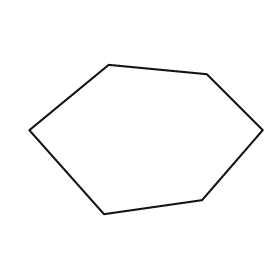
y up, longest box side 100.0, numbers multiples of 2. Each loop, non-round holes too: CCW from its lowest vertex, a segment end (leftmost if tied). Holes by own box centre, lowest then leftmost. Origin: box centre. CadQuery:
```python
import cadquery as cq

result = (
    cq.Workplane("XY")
    .moveTo(-18.0, -32.0)
    .lineTo(24.0, -26.0)
    .lineTo(50.0, 4.0)
    .lineTo(26.0, 28.0)
    .lineTo(-16.0, 32.0)
    .lineTo(-50.0, 4.0)
    .close()
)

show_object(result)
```